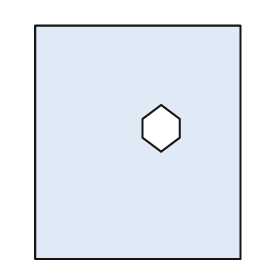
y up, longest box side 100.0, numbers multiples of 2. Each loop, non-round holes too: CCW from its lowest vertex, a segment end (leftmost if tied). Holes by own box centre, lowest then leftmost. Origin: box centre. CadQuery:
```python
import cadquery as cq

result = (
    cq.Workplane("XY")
    .moveTo(-44.0, -50.0)
    .lineTo(44.0, -50.0)
    .lineTo(44.0, 50.0)
    .lineTo(-44.0, 50.0)
    .close()
    .moveTo(10.0, -4.0)
    .lineTo(18.0, 2.0)
    .lineTo(18.0, 10.0)
    .lineTo(10.0, 16.0)
    .lineTo(2.0, 10.0)
    .lineTo(2.0, 2.0)
    .close()
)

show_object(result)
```